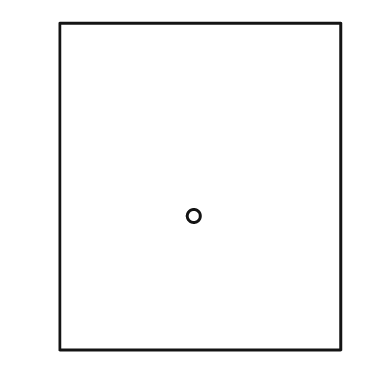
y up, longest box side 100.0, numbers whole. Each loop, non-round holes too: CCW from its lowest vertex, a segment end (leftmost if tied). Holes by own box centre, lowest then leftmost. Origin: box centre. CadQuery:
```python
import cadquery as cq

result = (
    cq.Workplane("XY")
    .moveTo(-43.0, -50.0)
    .lineTo(43.0, -50.0)
    .lineTo(43.0, 50.0)
    .lineTo(-43.0, 50.0)
    .close()
    .moveTo(-2.0, -9.0)
    .circle(2.0)
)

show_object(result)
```